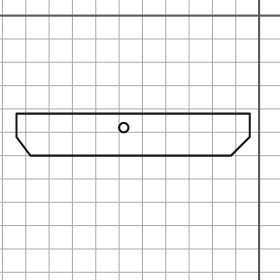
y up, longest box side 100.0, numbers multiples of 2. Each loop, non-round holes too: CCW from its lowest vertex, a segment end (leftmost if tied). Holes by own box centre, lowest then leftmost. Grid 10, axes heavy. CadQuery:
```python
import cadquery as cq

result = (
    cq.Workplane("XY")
    .moveTo(-98.0, -60.0)
    .lineTo(-12.0, -60.0)
    .lineTo(-4.0, -52.0)
    .lineTo(-4.0, -42.0)
    .lineTo(-104.0, -42.0)
    .lineTo(-104.0, -52.0)
    .close()
    .moveTo(-58.0, -48.0)
    .circle(2.0)
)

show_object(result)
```